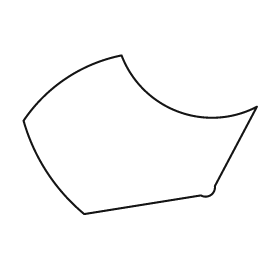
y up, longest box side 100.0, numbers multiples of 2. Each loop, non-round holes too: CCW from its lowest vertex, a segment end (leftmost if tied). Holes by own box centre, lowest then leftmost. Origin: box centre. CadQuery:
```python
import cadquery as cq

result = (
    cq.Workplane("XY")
    .moveTo(-24.0, -34.0)
    .lineTo(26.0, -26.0)
    .threePointArc((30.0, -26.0), (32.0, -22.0))
    .lineTo(50.0, 12.0)
    .threePointArc((16.0, 10.0), (-8.0, 34.0))
    .threePointArc((-32.0, 24.0), (-50.0, 6.0))
    .threePointArc((-40.0, -16.0), (-24.0, -34.0))
    .close()
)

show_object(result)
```